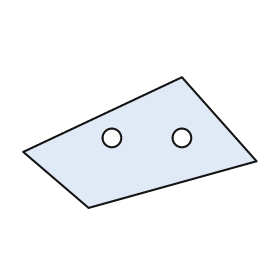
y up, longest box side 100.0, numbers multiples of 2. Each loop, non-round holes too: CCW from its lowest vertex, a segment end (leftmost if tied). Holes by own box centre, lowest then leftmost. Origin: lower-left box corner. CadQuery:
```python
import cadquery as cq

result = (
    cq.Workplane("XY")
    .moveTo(28.0, 0.0)
    .lineTo(100.0, 20.0)
    .lineTo(68.0, 56.0)
    .lineTo(0.0, 24.0)
    .close()
    .moveTo(38.0, 30.0)
    .circle(4.0)
    .moveTo(68.0, 30.0)
    .circle(4.0)
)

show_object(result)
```